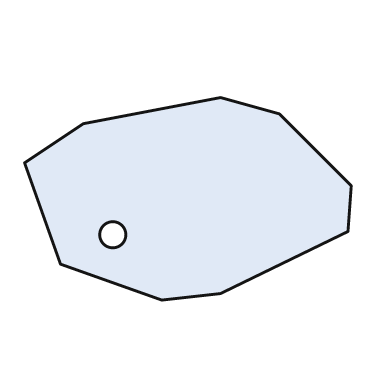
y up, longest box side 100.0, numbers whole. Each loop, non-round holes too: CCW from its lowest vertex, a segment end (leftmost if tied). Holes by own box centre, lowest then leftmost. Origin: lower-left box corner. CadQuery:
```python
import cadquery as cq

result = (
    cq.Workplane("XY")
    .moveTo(42.0, 0.0)
    .lineTo(60.0, 2.0)
    .lineTo(99.0, 21.0)
    .lineTo(100.0, 35.0)
    .lineTo(78.0, 57.0)
    .lineTo(60.0, 62.0)
    .lineTo(18.0, 54.0)
    .lineTo(0.0, 42.0)
    .lineTo(11.0, 11.0)
    .close()
    .moveTo(27.0, 20.0)
    .circle(4.0)
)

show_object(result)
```